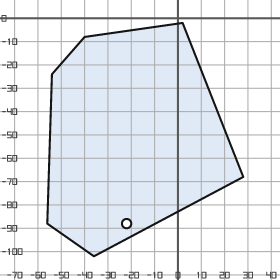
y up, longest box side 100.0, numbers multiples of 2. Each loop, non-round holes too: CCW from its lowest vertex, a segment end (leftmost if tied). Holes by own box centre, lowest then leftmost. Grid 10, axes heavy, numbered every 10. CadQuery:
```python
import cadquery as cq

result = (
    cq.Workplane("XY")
    .moveTo(-36.0, -102.0)
    .lineTo(28.0, -68.0)
    .lineTo(2.0, -2.0)
    .lineTo(-40.0, -8.0)
    .lineTo(-54.0, -24.0)
    .lineTo(-56.0, -88.0)
    .close()
    .moveTo(-22.0, -88.0)
    .circle(2.0)
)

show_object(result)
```